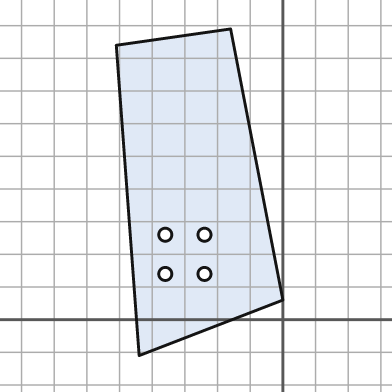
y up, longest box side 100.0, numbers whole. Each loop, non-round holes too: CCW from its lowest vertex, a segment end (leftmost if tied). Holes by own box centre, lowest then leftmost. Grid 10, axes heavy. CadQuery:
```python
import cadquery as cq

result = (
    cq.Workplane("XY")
    .moveTo(-44.0, -11.0)
    .lineTo(0.0, 6.0)
    .lineTo(-16.0, 89.0)
    .lineTo(-51.0, 84.0)
    .close()
    .moveTo(-36.0, 14.0)
    .circle(2.0)
    .moveTo(-24.0, 14.0)
    .circle(2.0)
    .moveTo(-36.0, 26.0)
    .circle(2.0)
    .moveTo(-24.0, 26.0)
    .circle(2.0)
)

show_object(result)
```